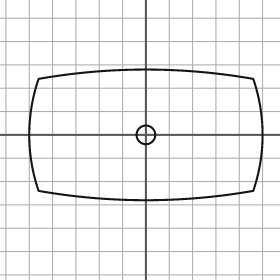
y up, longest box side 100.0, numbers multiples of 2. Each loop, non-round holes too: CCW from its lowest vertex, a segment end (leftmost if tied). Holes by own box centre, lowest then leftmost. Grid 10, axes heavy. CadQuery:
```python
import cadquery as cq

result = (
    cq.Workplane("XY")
    .moveTo(-46.0, -24.0)
    .threePointArc((0.0, -28.0), (46.0, -24.0))
    .threePointArc((50.0, 0.0), (46.0, 24.0))
    .threePointArc((0.0, 28.0), (-46.0, 24.0))
    .threePointArc((-50.0, 0.0), (-46.0, -24.0))
    .close()
    .moveTo(0.0, 0.0)
    .circle(4.0)
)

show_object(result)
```